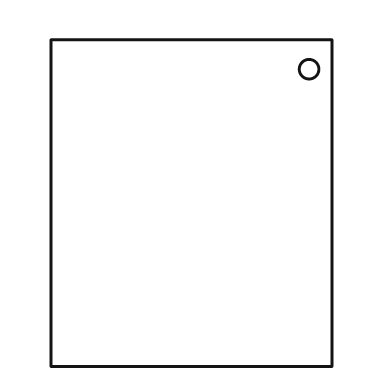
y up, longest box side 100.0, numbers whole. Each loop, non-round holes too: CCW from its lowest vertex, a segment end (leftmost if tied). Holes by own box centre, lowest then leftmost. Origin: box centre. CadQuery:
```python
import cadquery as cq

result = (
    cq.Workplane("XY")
    .moveTo(-43.0, -50.0)
    .lineTo(43.0, -50.0)
    .lineTo(43.0, 50.0)
    .lineTo(-43.0, 50.0)
    .close()
    .moveTo(36.0, 41.0)
    .circle(3.0)
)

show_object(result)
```